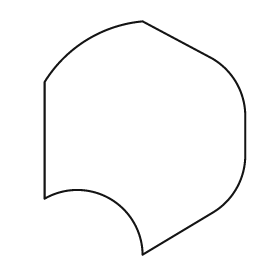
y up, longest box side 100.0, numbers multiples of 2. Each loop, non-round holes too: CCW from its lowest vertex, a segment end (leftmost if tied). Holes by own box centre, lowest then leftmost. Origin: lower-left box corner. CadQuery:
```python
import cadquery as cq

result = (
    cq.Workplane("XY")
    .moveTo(42.0, 0.0)
    .lineTo(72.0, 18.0)
    .threePointArc((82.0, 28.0), (86.0, 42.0))
    .lineTo(86.0, 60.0)
    .threePointArc((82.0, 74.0), (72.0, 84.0))
    .lineTo(42.0, 100.0)
    .threePointArc((18.0, 92.0), (0.0, 74.0))
    .lineTo(0.0, 24.0)
    .threePointArc((28.0, 24.0), (42.0, 0.0))
    .close()
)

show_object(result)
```